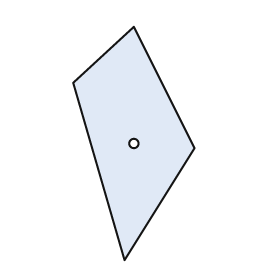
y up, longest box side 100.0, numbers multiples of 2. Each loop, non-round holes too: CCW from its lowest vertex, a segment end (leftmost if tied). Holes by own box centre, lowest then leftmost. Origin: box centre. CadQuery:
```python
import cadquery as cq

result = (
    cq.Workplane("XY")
    .moveTo(-4.0, -50.0)
    .lineTo(26.0, -2.0)
    .lineTo(0.0, 50.0)
    .lineTo(-26.0, 26.0)
    .close()
    .moveTo(0.0, 0.0)
    .circle(2.0)
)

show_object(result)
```